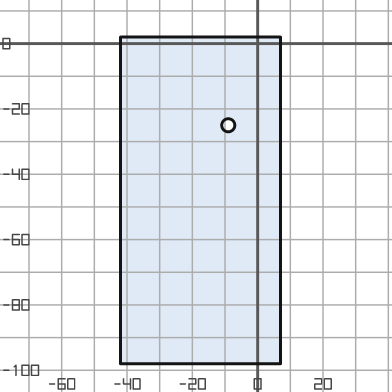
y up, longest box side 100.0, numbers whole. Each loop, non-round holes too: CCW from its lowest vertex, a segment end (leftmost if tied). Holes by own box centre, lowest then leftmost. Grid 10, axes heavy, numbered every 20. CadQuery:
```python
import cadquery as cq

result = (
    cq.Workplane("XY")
    .moveTo(-42.0, -98.0)
    .lineTo(7.0, -98.0)
    .lineTo(7.0, 2.0)
    .lineTo(-42.0, 2.0)
    .close()
    .moveTo(-9.0, -25.0)
    .circle(2.0)
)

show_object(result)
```